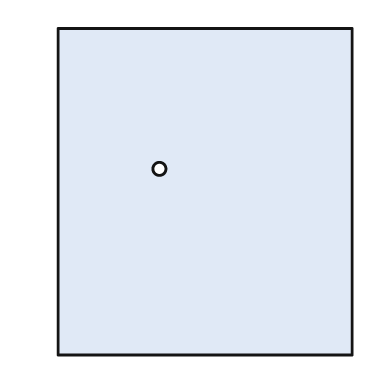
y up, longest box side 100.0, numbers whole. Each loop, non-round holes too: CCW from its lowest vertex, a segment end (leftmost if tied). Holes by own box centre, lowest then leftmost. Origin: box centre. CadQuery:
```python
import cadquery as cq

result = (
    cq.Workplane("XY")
    .moveTo(-45.0, -50.0)
    .lineTo(45.0, -50.0)
    .lineTo(45.0, 50.0)
    .lineTo(-45.0, 50.0)
    .close()
    .moveTo(-14.0, 7.0)
    .circle(2.0)
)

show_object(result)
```